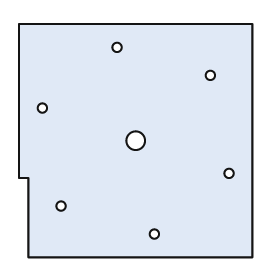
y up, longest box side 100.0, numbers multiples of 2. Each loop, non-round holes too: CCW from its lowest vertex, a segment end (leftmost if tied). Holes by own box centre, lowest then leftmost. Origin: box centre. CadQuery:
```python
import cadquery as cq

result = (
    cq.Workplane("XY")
    .moveTo(-46.0, -50.0)
    .lineTo(50.0, -50.0)
    .lineTo(50.0, 50.0)
    .lineTo(-50.0, 50.0)
    .lineTo(-50.0, -16.0)
    .lineTo(-46.0, -16.0)
    .close()
    .moveTo(8.0, -40.0)
    .circle(2.0)
    .moveTo(-32.0, -28.0)
    .circle(2.0)
    .moveTo(40.0, -14.0)
    .circle(2.0)
    .moveTo(0.0, 0.0)
    .circle(4.0)
    .moveTo(-40.0, 14.0)
    .circle(2.0)
    .moveTo(32.0, 28.0)
    .circle(2.0)
    .moveTo(-8.0, 40.0)
    .circle(2.0)
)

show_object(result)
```